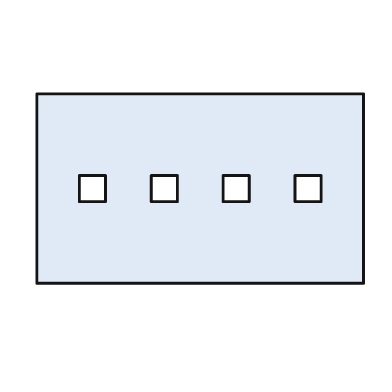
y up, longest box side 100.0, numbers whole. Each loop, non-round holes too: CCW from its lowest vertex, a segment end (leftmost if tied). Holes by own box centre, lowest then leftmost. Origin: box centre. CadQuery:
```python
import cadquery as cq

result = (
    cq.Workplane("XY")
    .moveTo(-50.0, -29.0)
    .lineTo(50.0, -29.0)
    .lineTo(50.0, 29.0)
    .lineTo(-50.0, 29.0)
    .close()
    .moveTo(-37.0, -4.0)
    .lineTo(-29.0, -4.0)
    .lineTo(-29.0, 4.0)
    .lineTo(-37.0, 4.0)
    .close()
    .moveTo(-15.0, -4.0)
    .lineTo(-7.0, -4.0)
    .lineTo(-7.0, 4.0)
    .lineTo(-15.0, 4.0)
    .close()
    .moveTo(7.0, -4.0)
    .lineTo(15.0, -4.0)
    .lineTo(15.0, 4.0)
    .lineTo(7.0, 4.0)
    .close()
    .moveTo(29.0, -4.0)
    .lineTo(37.0, -4.0)
    .lineTo(37.0, 4.0)
    .lineTo(29.0, 4.0)
    .close()
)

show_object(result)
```